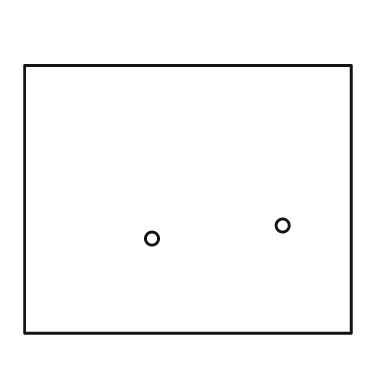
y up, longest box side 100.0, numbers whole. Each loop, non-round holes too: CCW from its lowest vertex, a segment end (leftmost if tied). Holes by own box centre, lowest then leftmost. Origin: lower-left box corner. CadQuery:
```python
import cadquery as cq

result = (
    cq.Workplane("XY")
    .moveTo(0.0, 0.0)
    .lineTo(100.0, 0.0)
    .lineTo(100.0, 82.0)
    .lineTo(0.0, 82.0)
    .close()
    .moveTo(39.0, 29.0)
    .circle(2.0)
    .moveTo(79.0, 33.0)
    .circle(2.0)
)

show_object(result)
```